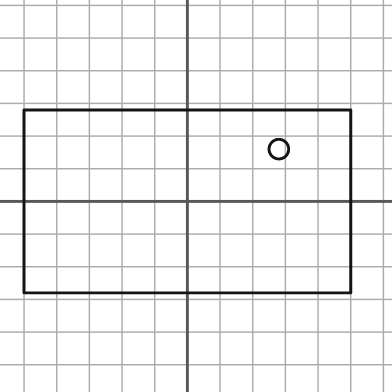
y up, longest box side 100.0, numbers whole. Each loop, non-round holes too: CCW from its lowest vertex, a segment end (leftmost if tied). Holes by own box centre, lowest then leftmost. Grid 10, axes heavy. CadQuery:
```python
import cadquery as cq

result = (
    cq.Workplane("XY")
    .moveTo(-50.0, -28.0)
    .lineTo(50.0, -28.0)
    .lineTo(50.0, 28.0)
    .lineTo(-50.0, 28.0)
    .close()
    .moveTo(28.0, 16.0)
    .circle(3.0)
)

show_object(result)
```